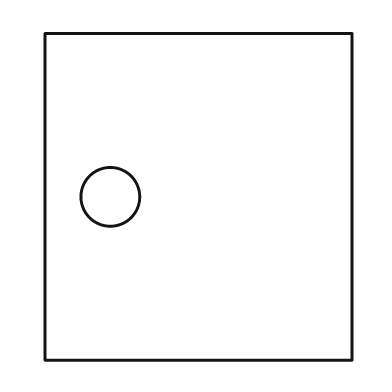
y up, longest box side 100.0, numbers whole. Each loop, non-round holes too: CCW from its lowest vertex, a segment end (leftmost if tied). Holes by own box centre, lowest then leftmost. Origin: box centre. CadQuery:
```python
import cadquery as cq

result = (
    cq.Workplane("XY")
    .moveTo(-47.0, -50.0)
    .lineTo(47.0, -50.0)
    .lineTo(47.0, 50.0)
    .lineTo(-47.0, 50.0)
    .close()
    .moveTo(-27.0, 0.0)
    .circle(9.0)
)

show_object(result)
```